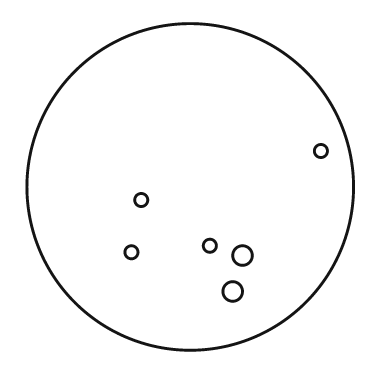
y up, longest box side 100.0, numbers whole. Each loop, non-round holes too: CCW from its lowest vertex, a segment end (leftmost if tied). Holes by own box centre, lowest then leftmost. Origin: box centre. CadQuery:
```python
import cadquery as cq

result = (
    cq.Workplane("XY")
    .moveTo(0.0, 0.0)
    .circle(50.0)
    .moveTo(13.0, -32.0)
    .circle(3.0)
    .moveTo(16.0, -21.0)
    .circle(3.0)
    .moveTo(-18.0, -20.0)
    .circle(2.0)
    .moveTo(6.0, -18.0)
    .circle(2.0)
    .moveTo(-15.0, -4.0)
    .circle(2.0)
    .moveTo(40.0, 11.0)
    .circle(2.0)
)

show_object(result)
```